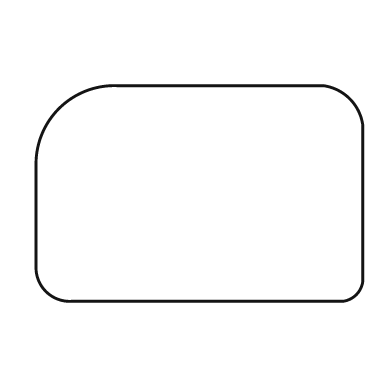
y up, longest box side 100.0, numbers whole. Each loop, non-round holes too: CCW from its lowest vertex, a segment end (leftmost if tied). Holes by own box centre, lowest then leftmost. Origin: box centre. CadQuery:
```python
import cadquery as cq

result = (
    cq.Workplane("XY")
    .moveTo(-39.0, -33.0)
    .lineTo(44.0, -33.0)
    .threePointArc((48.0, -31.0), (50.0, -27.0))
    .lineTo(50.0, 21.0)
    .threePointArc((46.0, 29.0), (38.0, 33.0))
    .lineTo(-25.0, 33.0)
    .threePointArc((-43.0, 26.0), (-50.0, 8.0))
    .lineTo(-50.0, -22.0)
    .threePointArc((-47.0, -30.0), (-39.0, -33.0))
    .close()
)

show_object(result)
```